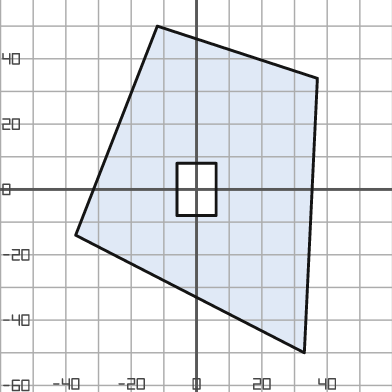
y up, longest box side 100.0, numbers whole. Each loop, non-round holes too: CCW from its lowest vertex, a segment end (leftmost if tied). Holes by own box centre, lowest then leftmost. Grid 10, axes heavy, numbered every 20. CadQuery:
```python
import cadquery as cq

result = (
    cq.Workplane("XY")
    .moveTo(33.0, -50.0)
    .lineTo(37.0, 34.0)
    .lineTo(-12.0, 50.0)
    .lineTo(-37.0, -14.0)
    .close()
    .moveTo(-6.0, -8.0)
    .lineTo(6.0, -8.0)
    .lineTo(6.0, 8.0)
    .lineTo(-6.0, 8.0)
    .close()
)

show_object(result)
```